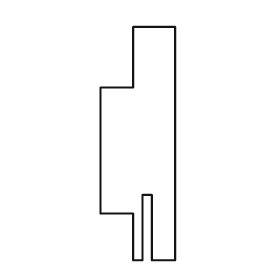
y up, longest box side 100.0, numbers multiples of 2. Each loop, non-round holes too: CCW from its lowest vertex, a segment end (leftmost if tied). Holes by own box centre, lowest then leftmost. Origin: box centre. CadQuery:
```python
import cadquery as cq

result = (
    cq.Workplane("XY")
    .moveTo(-2.0, -50.0)
    .lineTo(2.0, -50.0)
    .lineTo(2.0, -22.0)
    .lineTo(6.0, -22.0)
    .lineTo(6.0, -50.0)
    .lineTo(16.0, -50.0)
    .lineTo(16.0, 50.0)
    .lineTo(-2.0, 50.0)
    .lineTo(-2.0, 24.0)
    .lineTo(-16.0, 24.0)
    .lineTo(-16.0, -30.0)
    .lineTo(-2.0, -30.0)
    .close()
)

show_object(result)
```